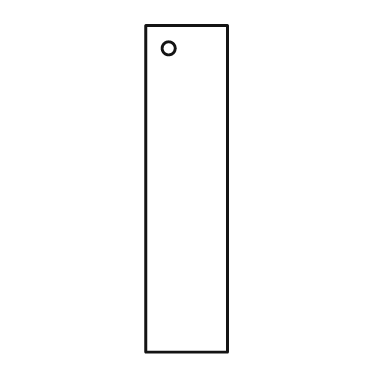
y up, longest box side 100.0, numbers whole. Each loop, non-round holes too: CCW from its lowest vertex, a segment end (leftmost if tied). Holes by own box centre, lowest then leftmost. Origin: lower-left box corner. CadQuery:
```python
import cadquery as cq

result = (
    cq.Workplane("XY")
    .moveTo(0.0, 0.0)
    .lineTo(25.0, 0.0)
    .lineTo(25.0, 100.0)
    .lineTo(0.0, 100.0)
    .close()
    .moveTo(7.0, 93.0)
    .circle(2.0)
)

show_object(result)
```